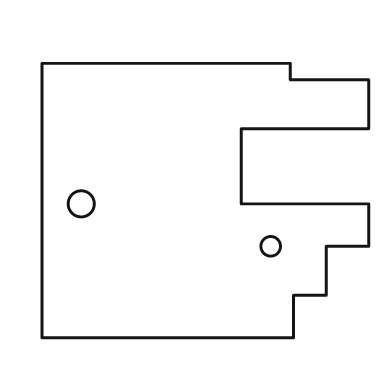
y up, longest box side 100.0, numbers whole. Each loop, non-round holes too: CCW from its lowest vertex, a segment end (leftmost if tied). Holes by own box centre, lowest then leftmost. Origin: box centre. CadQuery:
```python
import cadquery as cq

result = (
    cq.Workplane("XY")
    .moveTo(-50.0, -42.0)
    .lineTo(27.0, -42.0)
    .lineTo(27.0, -29.0)
    .lineTo(37.0, -29.0)
    .lineTo(37.0, -14.0)
    .lineTo(50.0, -14.0)
    .lineTo(50.0, -1.0)
    .lineTo(11.0, -1.0)
    .lineTo(11.0, 22.0)
    .lineTo(50.0, 22.0)
    .lineTo(50.0, 37.0)
    .lineTo(26.0, 37.0)
    .lineTo(26.0, 42.0)
    .lineTo(-50.0, 42.0)
    .close()
    .moveTo(20.0, -14.0)
    .circle(3.0)
    .moveTo(-38.0, -1.0)
    .circle(4.0)
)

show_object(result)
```